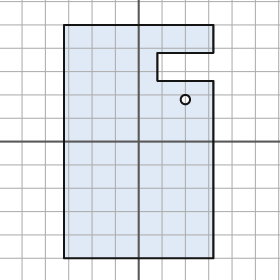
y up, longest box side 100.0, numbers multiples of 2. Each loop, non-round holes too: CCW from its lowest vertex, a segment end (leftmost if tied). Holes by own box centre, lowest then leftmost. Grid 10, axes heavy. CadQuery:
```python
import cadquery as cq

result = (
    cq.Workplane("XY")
    .moveTo(-32.0, -50.0)
    .lineTo(32.0, -50.0)
    .lineTo(32.0, 26.0)
    .lineTo(8.0, 26.0)
    .lineTo(8.0, 38.0)
    .lineTo(32.0, 38.0)
    .lineTo(32.0, 50.0)
    .lineTo(-32.0, 50.0)
    .close()
    .moveTo(20.0, 18.0)
    .circle(2.0)
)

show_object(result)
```